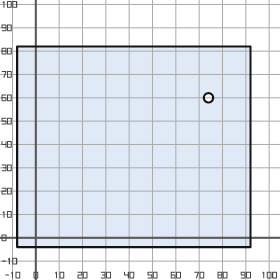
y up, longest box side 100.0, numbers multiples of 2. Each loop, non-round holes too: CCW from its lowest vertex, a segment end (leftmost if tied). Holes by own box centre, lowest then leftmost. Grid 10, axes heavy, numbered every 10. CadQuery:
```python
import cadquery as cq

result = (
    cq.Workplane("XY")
    .moveTo(-8.0, -4.0)
    .lineTo(92.0, -4.0)
    .lineTo(92.0, 82.0)
    .lineTo(-8.0, 82.0)
    .close()
    .moveTo(74.0, 60.0)
    .circle(2.0)
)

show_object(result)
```